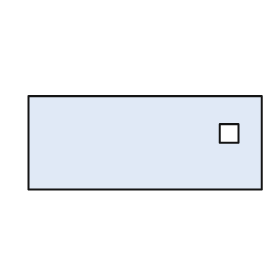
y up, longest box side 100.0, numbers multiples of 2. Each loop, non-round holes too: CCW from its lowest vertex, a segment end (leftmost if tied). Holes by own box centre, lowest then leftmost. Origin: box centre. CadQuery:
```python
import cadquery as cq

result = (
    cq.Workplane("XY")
    .moveTo(-50.0, -20.0)
    .lineTo(50.0, -20.0)
    .lineTo(50.0, 20.0)
    .lineTo(-50.0, 20.0)
    .close()
    .moveTo(32.0, 0.0)
    .lineTo(40.0, 0.0)
    .lineTo(40.0, 8.0)
    .lineTo(32.0, 8.0)
    .close()
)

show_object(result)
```